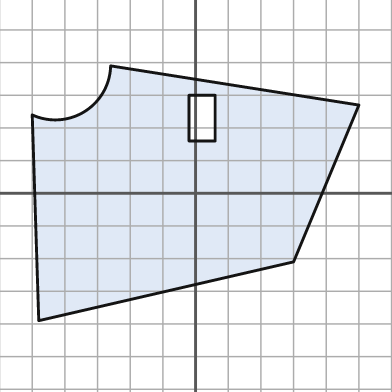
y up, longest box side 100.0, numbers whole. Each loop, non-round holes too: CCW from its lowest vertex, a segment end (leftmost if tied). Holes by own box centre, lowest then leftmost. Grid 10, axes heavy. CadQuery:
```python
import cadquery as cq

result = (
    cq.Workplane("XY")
    .moveTo(-48.0, -39.0)
    .lineTo(30.0, -21.0)
    .lineTo(50.0, 27.0)
    .lineTo(-26.0, 39.0)
    .threePointArc((-34.0, 25.0), (-50.0, 24.0))
    .close()
    .moveTo(-2.0, 16.0)
    .lineTo(6.0, 16.0)
    .lineTo(6.0, 30.0)
    .lineTo(-2.0, 30.0)
    .close()
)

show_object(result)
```